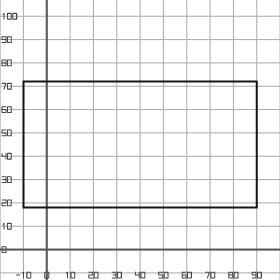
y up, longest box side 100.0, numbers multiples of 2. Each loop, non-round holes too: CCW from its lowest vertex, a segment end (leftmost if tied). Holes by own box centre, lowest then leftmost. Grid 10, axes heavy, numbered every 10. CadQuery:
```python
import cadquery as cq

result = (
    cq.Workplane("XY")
    .moveTo(-10.0, 18.0)
    .lineTo(90.0, 18.0)
    .lineTo(90.0, 72.0)
    .lineTo(-10.0, 72.0)
    .close()
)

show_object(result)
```